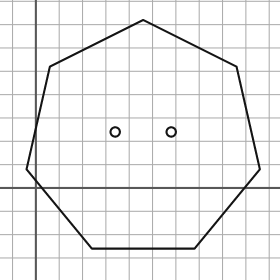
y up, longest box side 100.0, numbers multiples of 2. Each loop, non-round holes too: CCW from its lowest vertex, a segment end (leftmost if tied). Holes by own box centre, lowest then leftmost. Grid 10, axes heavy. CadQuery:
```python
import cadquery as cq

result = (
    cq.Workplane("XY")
    .moveTo(24.0, -26.0)
    .lineTo(68.0, -26.0)
    .lineTo(96.0, 8.0)
    .lineTo(86.0, 52.0)
    .lineTo(46.0, 72.0)
    .lineTo(6.0, 52.0)
    .lineTo(-4.0, 8.0)
    .close()
    .moveTo(34.0, 24.0)
    .circle(2.0)
    .moveTo(58.0, 24.0)
    .circle(2.0)
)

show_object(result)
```